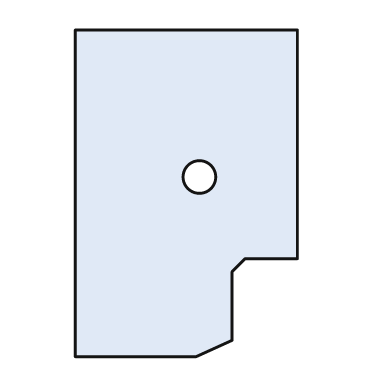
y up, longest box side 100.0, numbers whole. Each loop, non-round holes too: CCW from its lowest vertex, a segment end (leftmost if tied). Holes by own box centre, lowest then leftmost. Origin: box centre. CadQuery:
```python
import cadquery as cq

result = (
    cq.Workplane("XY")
    .moveTo(-34.0, -50.0)
    .lineTo(3.0, -50.0)
    .lineTo(14.0, -45.0)
    .lineTo(14.0, -24.0)
    .lineTo(18.0, -20.0)
    .lineTo(34.0, -20.0)
    .lineTo(34.0, 50.0)
    .lineTo(-34.0, 50.0)
    .close()
    .moveTo(4.0, 5.0)
    .circle(5.0)
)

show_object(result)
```